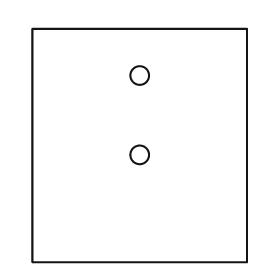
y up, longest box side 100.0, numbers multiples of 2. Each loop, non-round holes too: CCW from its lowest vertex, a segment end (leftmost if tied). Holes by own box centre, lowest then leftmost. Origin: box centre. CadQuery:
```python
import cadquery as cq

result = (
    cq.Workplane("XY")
    .moveTo(-46.0, -50.0)
    .lineTo(46.0, -50.0)
    .lineTo(46.0, 50.0)
    .lineTo(-46.0, 50.0)
    .close()
    .moveTo(0.0, -4.0)
    .circle(4.0)
    .moveTo(0.0, 30.0)
    .circle(4.0)
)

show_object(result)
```